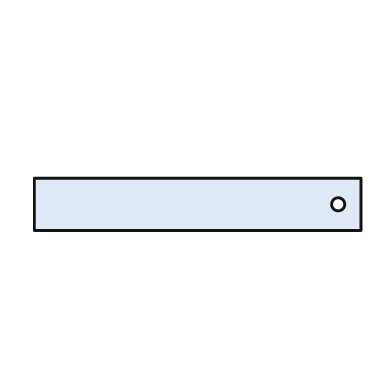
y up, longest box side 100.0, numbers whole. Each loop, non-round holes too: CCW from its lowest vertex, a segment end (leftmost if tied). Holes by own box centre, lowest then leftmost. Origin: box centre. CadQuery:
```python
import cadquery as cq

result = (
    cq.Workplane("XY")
    .moveTo(-50.0, -8.0)
    .lineTo(50.0, -8.0)
    .lineTo(50.0, 8.0)
    .lineTo(-50.0, 8.0)
    .close()
    .moveTo(43.0, 0.0)
    .circle(2.0)
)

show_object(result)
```